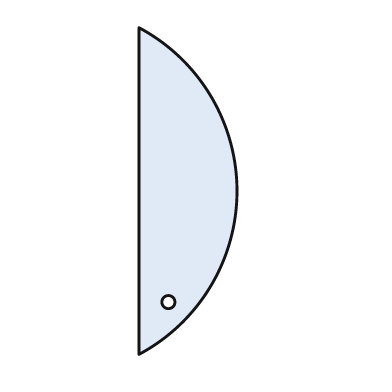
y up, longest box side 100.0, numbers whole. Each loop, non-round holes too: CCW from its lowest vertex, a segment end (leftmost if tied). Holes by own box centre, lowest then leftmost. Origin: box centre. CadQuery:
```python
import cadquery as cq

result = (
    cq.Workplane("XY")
    .moveTo(-15.0, -50.0)
    .threePointArc((15.0, 0.0), (-15.0, 50.0))
    .close()
    .moveTo(-6.0, -34.0)
    .circle(2.0)
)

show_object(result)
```